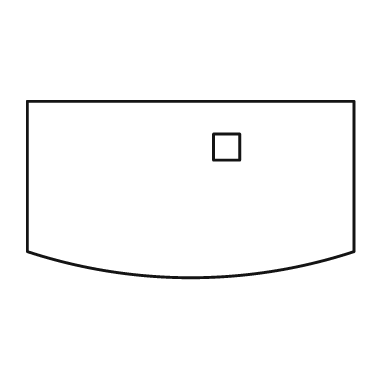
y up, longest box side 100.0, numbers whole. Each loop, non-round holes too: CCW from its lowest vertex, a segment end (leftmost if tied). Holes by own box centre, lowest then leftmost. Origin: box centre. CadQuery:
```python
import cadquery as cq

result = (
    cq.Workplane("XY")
    .moveTo(-50.0, -19.0)
    .threePointArc((0.0, -27.0), (50.0, -19.0))
    .lineTo(50.0, 27.0)
    .lineTo(-50.0, 27.0)
    .close()
    .moveTo(7.0, 9.0)
    .lineTo(15.0, 9.0)
    .lineTo(15.0, 17.0)
    .lineTo(7.0, 17.0)
    .close()
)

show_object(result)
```